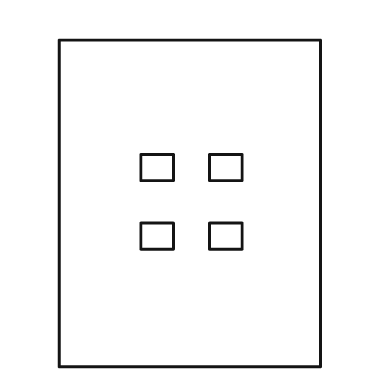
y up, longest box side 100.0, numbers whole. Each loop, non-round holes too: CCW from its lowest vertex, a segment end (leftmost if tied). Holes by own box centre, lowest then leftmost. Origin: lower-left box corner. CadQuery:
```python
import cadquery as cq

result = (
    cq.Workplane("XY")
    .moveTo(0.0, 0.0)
    .lineTo(80.0, 0.0)
    .lineTo(80.0, 100.0)
    .lineTo(0.0, 100.0)
    .close()
    .moveTo(25.0, 36.0)
    .lineTo(35.0, 36.0)
    .lineTo(35.0, 44.0)
    .lineTo(25.0, 44.0)
    .close()
    .moveTo(46.0, 36.0)
    .lineTo(56.0, 36.0)
    .lineTo(56.0, 44.0)
    .lineTo(46.0, 44.0)
    .close()
    .moveTo(25.0, 57.0)
    .lineTo(35.0, 57.0)
    .lineTo(35.0, 65.0)
    .lineTo(25.0, 65.0)
    .close()
    .moveTo(46.0, 57.0)
    .lineTo(56.0, 57.0)
    .lineTo(56.0, 65.0)
    .lineTo(46.0, 65.0)
    .close()
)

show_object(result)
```